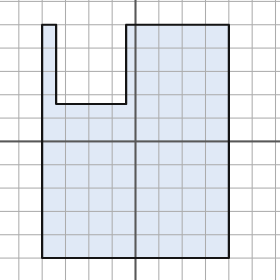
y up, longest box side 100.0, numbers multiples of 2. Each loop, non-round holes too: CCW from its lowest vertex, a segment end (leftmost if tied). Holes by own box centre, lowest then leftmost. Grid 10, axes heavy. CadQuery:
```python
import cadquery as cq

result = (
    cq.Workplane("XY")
    .moveTo(-40.0, -50.0)
    .lineTo(40.0, -50.0)
    .lineTo(40.0, 50.0)
    .lineTo(-4.0, 50.0)
    .lineTo(-4.0, 16.0)
    .lineTo(-34.0, 16.0)
    .lineTo(-34.0, 50.0)
    .lineTo(-40.0, 50.0)
    .close()
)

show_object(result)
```